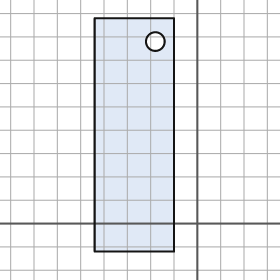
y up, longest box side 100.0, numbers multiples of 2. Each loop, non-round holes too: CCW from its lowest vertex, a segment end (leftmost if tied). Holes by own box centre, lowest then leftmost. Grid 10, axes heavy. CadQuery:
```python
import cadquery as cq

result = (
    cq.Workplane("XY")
    .moveTo(-44.0, -12.0)
    .lineTo(-10.0, -12.0)
    .lineTo(-10.0, 88.0)
    .lineTo(-44.0, 88.0)
    .close()
    .moveTo(-18.0, 78.0)
    .circle(4.0)
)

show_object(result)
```